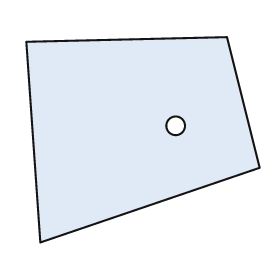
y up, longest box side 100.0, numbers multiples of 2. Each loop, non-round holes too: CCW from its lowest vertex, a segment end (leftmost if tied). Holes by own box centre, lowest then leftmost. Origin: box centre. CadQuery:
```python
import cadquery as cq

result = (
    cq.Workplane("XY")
    .moveTo(-44.0, -44.0)
    .lineTo(50.0, -12.0)
    .lineTo(36.0, 44.0)
    .lineTo(-50.0, 42.0)
    .close()
    .moveTo(14.0, 6.0)
    .circle(4.0)
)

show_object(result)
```